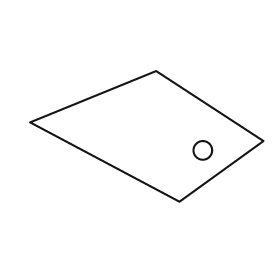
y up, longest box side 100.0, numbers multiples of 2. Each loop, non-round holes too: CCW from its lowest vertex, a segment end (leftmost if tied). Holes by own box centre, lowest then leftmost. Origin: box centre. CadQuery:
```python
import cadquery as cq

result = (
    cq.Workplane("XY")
    .moveTo(14.0, -28.0)
    .lineTo(50.0, -2.0)
    .lineTo(4.0, 28.0)
    .lineTo(-50.0, 6.0)
    .close()
    .moveTo(24.0, -6.0)
    .circle(4.0)
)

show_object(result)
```